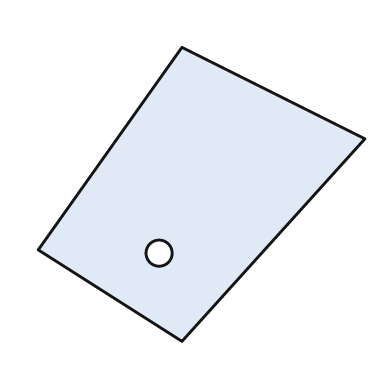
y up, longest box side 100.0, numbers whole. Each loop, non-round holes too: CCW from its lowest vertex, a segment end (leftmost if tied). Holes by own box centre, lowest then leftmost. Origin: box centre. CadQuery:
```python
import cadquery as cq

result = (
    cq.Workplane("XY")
    .moveTo(-6.0, -45.0)
    .lineTo(50.0, 17.0)
    .lineTo(-6.0, 45.0)
    .lineTo(-50.0, -17.0)
    .close()
    .moveTo(-13.0, -18.0)
    .circle(4.0)
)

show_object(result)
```